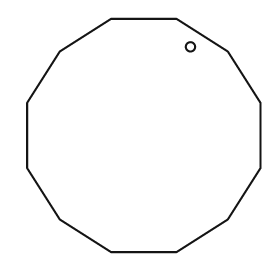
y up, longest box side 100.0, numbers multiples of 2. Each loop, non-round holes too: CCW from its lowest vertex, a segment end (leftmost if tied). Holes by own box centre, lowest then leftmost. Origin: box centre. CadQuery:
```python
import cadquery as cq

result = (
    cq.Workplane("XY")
    .moveTo(-14.0, -50.0)
    .lineTo(14.0, -50.0)
    .lineTo(36.0, -36.0)
    .lineTo(50.0, -14.0)
    .lineTo(50.0, 14.0)
    .lineTo(36.0, 36.0)
    .lineTo(14.0, 50.0)
    .lineTo(-14.0, 50.0)
    .lineTo(-36.0, 36.0)
    .lineTo(-50.0, 14.0)
    .lineTo(-50.0, -14.0)
    .lineTo(-36.0, -36.0)
    .close()
    .moveTo(20.0, 38.0)
    .circle(2.0)
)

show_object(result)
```